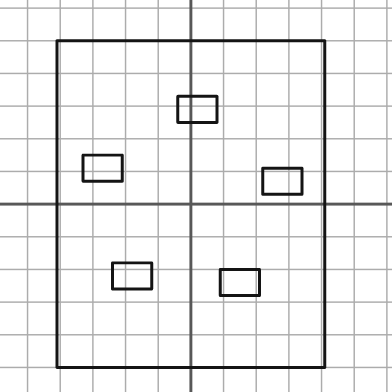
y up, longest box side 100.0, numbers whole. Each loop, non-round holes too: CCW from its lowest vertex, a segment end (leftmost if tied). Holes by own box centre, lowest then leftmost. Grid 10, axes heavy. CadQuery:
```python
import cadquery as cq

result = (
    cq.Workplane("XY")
    .moveTo(-41.0, -50.0)
    .lineTo(41.0, -50.0)
    .lineTo(41.0, 50.0)
    .lineTo(-41.0, 50.0)
    .close()
    .moveTo(9.0, -28.0)
    .lineTo(21.0, -28.0)
    .lineTo(21.0, -20.0)
    .lineTo(9.0, -20.0)
    .close()
    .moveTo(-24.0, -26.0)
    .lineTo(-12.0, -26.0)
    .lineTo(-12.0, -18.0)
    .lineTo(-24.0, -18.0)
    .close()
    .moveTo(22.0, 3.0)
    .lineTo(34.0, 3.0)
    .lineTo(34.0, 11.0)
    .lineTo(22.0, 11.0)
    .close()
    .moveTo(-33.0, 7.0)
    .lineTo(-21.0, 7.0)
    .lineTo(-21.0, 15.0)
    .lineTo(-33.0, 15.0)
    .close()
    .moveTo(-4.0, 25.0)
    .lineTo(8.0, 25.0)
    .lineTo(8.0, 33.0)
    .lineTo(-4.0, 33.0)
    .close()
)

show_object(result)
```